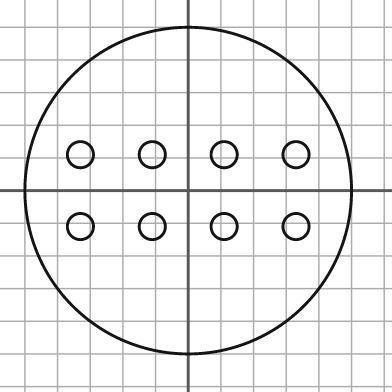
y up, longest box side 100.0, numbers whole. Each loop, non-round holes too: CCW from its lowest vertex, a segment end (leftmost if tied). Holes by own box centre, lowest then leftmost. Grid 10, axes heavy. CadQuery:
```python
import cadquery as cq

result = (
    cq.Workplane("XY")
    .moveTo(0.0, 0.0)
    .circle(50.0)
    .moveTo(-33.0, -11.0)
    .circle(4.0)
    .moveTo(-11.0, -11.0)
    .circle(4.0)
    .moveTo(11.0, -11.0)
    .circle(4.0)
    .moveTo(33.0, -11.0)
    .circle(4.0)
    .moveTo(-33.0, 11.0)
    .circle(4.0)
    .moveTo(-11.0, 11.0)
    .circle(4.0)
    .moveTo(11.0, 11.0)
    .circle(4.0)
    .moveTo(33.0, 11.0)
    .circle(4.0)
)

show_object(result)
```